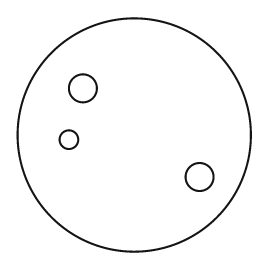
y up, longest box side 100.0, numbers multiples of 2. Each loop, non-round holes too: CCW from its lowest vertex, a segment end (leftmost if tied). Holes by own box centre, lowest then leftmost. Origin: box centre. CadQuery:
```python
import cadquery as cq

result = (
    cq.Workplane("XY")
    .moveTo(0.0, 0.0)
    .circle(50.0)
    .moveTo(28.0, -18.0)
    .circle(6.0)
    .moveTo(-28.0, -2.0)
    .circle(4.0)
    .moveTo(-22.0, 20.0)
    .circle(6.0)
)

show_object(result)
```